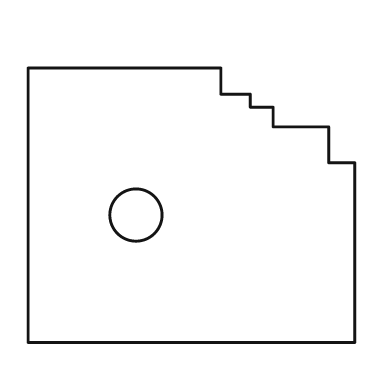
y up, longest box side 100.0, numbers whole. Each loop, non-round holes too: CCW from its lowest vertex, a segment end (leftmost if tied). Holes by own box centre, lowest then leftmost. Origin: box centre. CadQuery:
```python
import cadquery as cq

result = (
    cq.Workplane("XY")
    .moveTo(-50.0, -42.0)
    .lineTo(50.0, -42.0)
    .lineTo(50.0, 13.0)
    .lineTo(42.0, 13.0)
    .lineTo(42.0, 24.0)
    .lineTo(25.0, 24.0)
    .lineTo(25.0, 30.0)
    .lineTo(18.0, 30.0)
    .lineTo(18.0, 34.0)
    .lineTo(9.0, 34.0)
    .lineTo(9.0, 42.0)
    .lineTo(-50.0, 42.0)
    .close()
    .moveTo(-17.0, -3.0)
    .circle(8.0)
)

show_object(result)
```